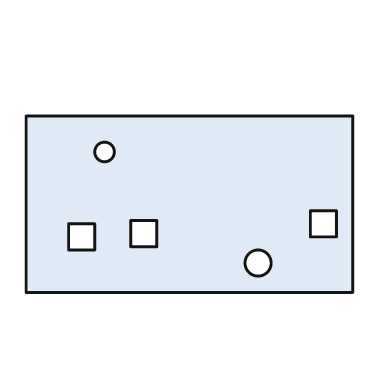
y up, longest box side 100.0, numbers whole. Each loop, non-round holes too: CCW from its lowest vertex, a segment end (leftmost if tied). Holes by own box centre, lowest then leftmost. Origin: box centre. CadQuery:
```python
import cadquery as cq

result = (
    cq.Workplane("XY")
    .moveTo(-50.0, -27.0)
    .lineTo(50.0, -27.0)
    .lineTo(50.0, 27.0)
    .lineTo(-50.0, 27.0)
    .close()
    .moveTo(21.0, -18.0)
    .circle(4.0)
    .moveTo(-37.0, -14.0)
    .lineTo(-29.0, -14.0)
    .lineTo(-29.0, -6.0)
    .lineTo(-37.0, -6.0)
    .close()
    .moveTo(-18.0, -13.0)
    .lineTo(-10.0, -13.0)
    .lineTo(-10.0, -5.0)
    .lineTo(-18.0, -5.0)
    .close()
    .moveTo(37.0, -10.0)
    .lineTo(45.0, -10.0)
    .lineTo(45.0, -2.0)
    .lineTo(37.0, -2.0)
    .close()
    .moveTo(-26.0, 16.0)
    .circle(3.0)
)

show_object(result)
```